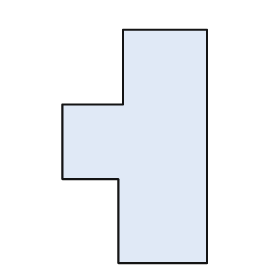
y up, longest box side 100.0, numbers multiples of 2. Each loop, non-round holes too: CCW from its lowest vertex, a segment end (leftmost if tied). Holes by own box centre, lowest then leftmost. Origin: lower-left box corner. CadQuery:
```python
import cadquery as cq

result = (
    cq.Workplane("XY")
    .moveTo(24.0, 0.0)
    .lineTo(62.0, 0.0)
    .lineTo(62.0, 100.0)
    .lineTo(26.0, 100.0)
    .lineTo(26.0, 68.0)
    .lineTo(0.0, 68.0)
    .lineTo(0.0, 36.0)
    .lineTo(24.0, 36.0)
    .close()
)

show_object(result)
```